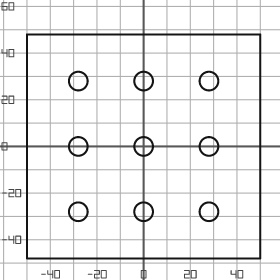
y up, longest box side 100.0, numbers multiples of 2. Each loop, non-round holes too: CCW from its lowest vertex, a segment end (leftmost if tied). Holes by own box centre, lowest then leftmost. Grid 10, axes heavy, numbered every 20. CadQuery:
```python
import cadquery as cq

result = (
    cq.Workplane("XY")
    .moveTo(-50.0, -48.0)
    .lineTo(50.0, -48.0)
    .lineTo(50.0, 48.0)
    .lineTo(-50.0, 48.0)
    .close()
    .moveTo(-28.0, -28.0)
    .circle(4.0)
    .moveTo(0.0, -28.0)
    .circle(4.0)
    .moveTo(28.0, -28.0)
    .circle(4.0)
    .moveTo(-28.0, 0.0)
    .circle(4.0)
    .moveTo(0.0, 0.0)
    .circle(4.0)
    .moveTo(28.0, 0.0)
    .circle(4.0)
    .moveTo(-28.0, 28.0)
    .circle(4.0)
    .moveTo(0.0, 28.0)
    .circle(4.0)
    .moveTo(28.0, 28.0)
    .circle(4.0)
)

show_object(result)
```